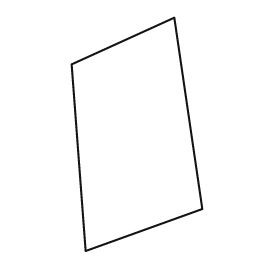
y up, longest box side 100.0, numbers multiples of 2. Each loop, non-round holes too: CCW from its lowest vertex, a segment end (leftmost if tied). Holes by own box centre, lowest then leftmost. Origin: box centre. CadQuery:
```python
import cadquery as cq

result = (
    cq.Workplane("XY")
    .moveTo(-22.0, -50.0)
    .lineTo(28.0, -32.0)
    .lineTo(16.0, 50.0)
    .lineTo(-28.0, 30.0)
    .close()
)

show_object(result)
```